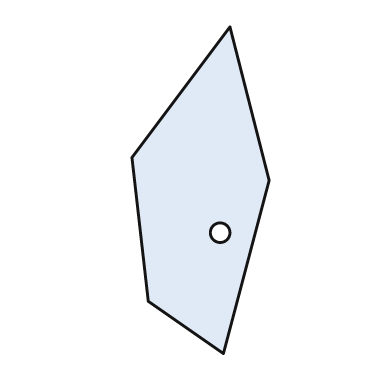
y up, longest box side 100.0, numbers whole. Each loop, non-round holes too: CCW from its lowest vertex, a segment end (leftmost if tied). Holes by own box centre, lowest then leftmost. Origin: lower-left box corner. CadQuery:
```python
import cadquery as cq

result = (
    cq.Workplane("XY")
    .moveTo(28.0, 0.0)
    .lineTo(42.0, 53.0)
    .lineTo(30.0, 100.0)
    .lineTo(0.0, 60.0)
    .lineTo(5.0, 16.0)
    .close()
    .moveTo(27.0, 37.0)
    .circle(3.0)
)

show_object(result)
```